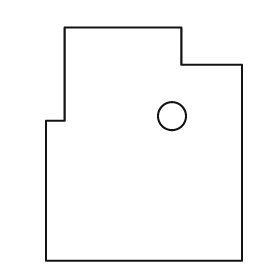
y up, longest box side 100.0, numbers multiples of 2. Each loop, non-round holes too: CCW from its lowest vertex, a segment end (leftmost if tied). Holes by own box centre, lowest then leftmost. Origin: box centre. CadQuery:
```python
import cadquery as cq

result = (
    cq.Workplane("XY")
    .moveTo(-42.0, -50.0)
    .lineTo(42.0, -50.0)
    .lineTo(42.0, 34.0)
    .lineTo(16.0, 34.0)
    .lineTo(16.0, 50.0)
    .lineTo(-34.0, 50.0)
    .lineTo(-34.0, 10.0)
    .lineTo(-42.0, 10.0)
    .close()
    .moveTo(12.0, 12.0)
    .circle(6.0)
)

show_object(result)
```